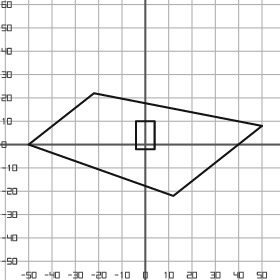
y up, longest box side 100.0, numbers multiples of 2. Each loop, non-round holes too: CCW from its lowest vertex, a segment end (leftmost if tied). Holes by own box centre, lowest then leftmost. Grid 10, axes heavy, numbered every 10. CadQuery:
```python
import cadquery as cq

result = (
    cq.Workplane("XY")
    .moveTo(12.0, -22.0)
    .lineTo(50.0, 8.0)
    .lineTo(-22.0, 22.0)
    .lineTo(-50.0, 0.0)
    .close()
    .moveTo(-4.0, -2.0)
    .lineTo(4.0, -2.0)
    .lineTo(4.0, 10.0)
    .lineTo(-4.0, 10.0)
    .close()
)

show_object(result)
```